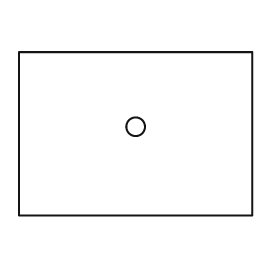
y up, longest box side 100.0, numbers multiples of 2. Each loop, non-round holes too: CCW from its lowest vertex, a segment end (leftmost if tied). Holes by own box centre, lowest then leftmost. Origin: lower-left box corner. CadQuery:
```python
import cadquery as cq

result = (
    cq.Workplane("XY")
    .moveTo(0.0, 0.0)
    .lineTo(100.0, 0.0)
    .lineTo(100.0, 70.0)
    .lineTo(0.0, 70.0)
    .close()
    .moveTo(50.0, 38.0)
    .circle(4.0)
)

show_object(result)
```